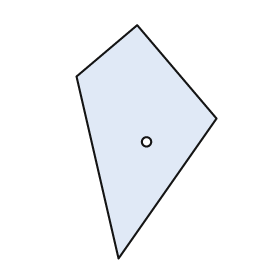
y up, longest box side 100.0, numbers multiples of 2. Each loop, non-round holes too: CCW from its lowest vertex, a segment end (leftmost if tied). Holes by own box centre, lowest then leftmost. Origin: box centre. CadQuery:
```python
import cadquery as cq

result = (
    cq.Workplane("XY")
    .moveTo(-12.0, -50.0)
    .lineTo(30.0, 10.0)
    .lineTo(-4.0, 50.0)
    .lineTo(-30.0, 28.0)
    .close()
    .moveTo(0.0, 0.0)
    .circle(2.0)
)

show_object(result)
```